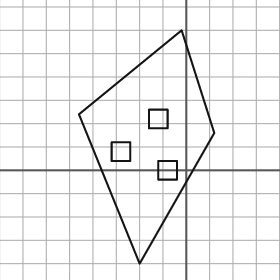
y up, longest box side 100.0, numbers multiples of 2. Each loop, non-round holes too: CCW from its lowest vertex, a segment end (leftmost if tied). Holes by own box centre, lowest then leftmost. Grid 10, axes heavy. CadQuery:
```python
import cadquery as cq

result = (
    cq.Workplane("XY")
    .moveTo(-20.0, -40.0)
    .lineTo(12.0, 16.0)
    .lineTo(-2.0, 60.0)
    .lineTo(-46.0, 24.0)
    .close()
    .moveTo(-12.0, -4.0)
    .lineTo(-4.0, -4.0)
    .lineTo(-4.0, 4.0)
    .lineTo(-12.0, 4.0)
    .close()
    .moveTo(-32.0, 4.0)
    .lineTo(-24.0, 4.0)
    .lineTo(-24.0, 12.0)
    .lineTo(-32.0, 12.0)
    .close()
    .moveTo(-16.0, 18.0)
    .lineTo(-8.0, 18.0)
    .lineTo(-8.0, 26.0)
    .lineTo(-16.0, 26.0)
    .close()
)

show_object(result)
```